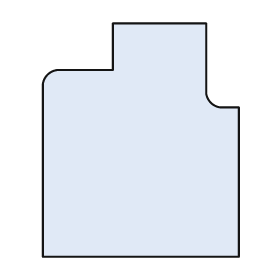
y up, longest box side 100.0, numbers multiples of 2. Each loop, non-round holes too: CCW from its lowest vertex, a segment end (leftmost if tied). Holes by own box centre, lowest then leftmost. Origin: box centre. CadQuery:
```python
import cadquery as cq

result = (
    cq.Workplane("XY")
    .moveTo(-42.0, -50.0)
    .lineTo(42.0, -50.0)
    .lineTo(42.0, 14.0)
    .lineTo(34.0, 14.0)
    .threePointArc((30.0, 16.0), (28.0, 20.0))
    .lineTo(28.0, 50.0)
    .lineTo(-12.0, 50.0)
    .lineTo(-12.0, 30.0)
    .lineTo(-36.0, 30.0)
    .threePointArc((-40.0, 28.0), (-42.0, 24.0))
    .close()
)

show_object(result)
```